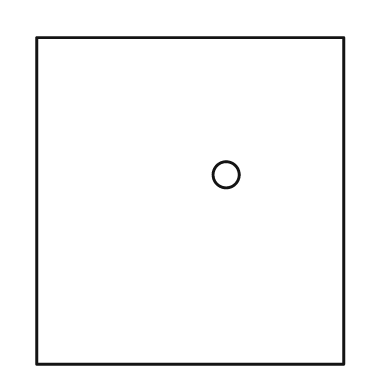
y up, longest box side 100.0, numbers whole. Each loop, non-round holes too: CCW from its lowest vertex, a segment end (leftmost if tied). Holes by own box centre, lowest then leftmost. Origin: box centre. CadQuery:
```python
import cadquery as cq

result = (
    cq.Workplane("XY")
    .moveTo(-47.0, -50.0)
    .lineTo(47.0, -50.0)
    .lineTo(47.0, 50.0)
    .lineTo(-47.0, 50.0)
    .close()
    .moveTo(11.0, 8.0)
    .circle(4.0)
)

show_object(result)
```